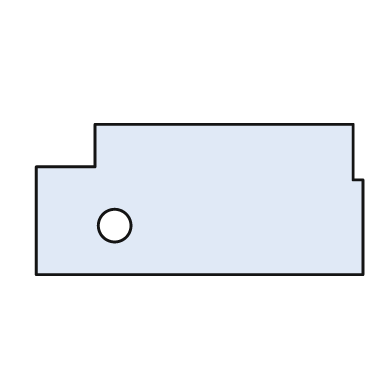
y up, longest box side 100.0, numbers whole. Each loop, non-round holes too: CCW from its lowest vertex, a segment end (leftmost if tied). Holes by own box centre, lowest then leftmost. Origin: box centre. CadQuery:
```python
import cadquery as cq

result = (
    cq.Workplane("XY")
    .moveTo(-50.0, -23.0)
    .lineTo(50.0, -23.0)
    .lineTo(50.0, 6.0)
    .lineTo(47.0, 6.0)
    .lineTo(47.0, 23.0)
    .lineTo(-32.0, 23.0)
    .lineTo(-32.0, 10.0)
    .lineTo(-50.0, 10.0)
    .close()
    .moveTo(-26.0, -8.0)
    .circle(5.0)
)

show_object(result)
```